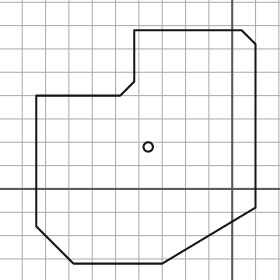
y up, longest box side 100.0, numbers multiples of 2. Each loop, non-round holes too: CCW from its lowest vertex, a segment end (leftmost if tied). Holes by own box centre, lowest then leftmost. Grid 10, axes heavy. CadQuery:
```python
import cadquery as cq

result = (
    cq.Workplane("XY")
    .moveTo(-68.0, -32.0)
    .lineTo(-30.0, -32.0)
    .lineTo(10.0, -8.0)
    .lineTo(10.0, 62.0)
    .lineTo(4.0, 68.0)
    .lineTo(-42.0, 68.0)
    .lineTo(-42.0, 46.0)
    .lineTo(-48.0, 40.0)
    .lineTo(-84.0, 40.0)
    .lineTo(-84.0, -16.0)
    .close()
    .moveTo(-36.0, 18.0)
    .circle(2.0)
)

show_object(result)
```